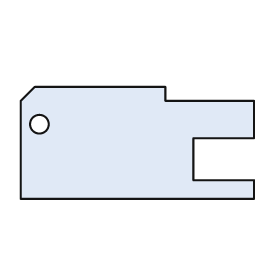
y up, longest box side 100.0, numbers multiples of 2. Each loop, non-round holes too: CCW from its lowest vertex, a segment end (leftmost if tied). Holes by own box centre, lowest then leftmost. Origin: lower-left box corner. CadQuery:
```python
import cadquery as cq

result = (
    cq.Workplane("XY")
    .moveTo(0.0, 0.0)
    .lineTo(100.0, 0.0)
    .lineTo(100.0, 8.0)
    .lineTo(74.0, 8.0)
    .lineTo(74.0, 26.0)
    .lineTo(100.0, 26.0)
    .lineTo(100.0, 42.0)
    .lineTo(62.0, 42.0)
    .lineTo(62.0, 48.0)
    .lineTo(6.0, 48.0)
    .lineTo(0.0, 42.0)
    .close()
    .moveTo(8.0, 32.0)
    .circle(4.0)
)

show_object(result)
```